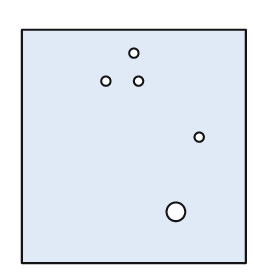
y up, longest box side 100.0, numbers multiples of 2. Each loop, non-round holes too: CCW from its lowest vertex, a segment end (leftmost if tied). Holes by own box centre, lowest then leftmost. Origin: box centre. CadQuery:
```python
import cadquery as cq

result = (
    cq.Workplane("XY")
    .moveTo(-48.0, -50.0)
    .lineTo(48.0, -50.0)
    .lineTo(48.0, 50.0)
    .lineTo(-48.0, 50.0)
    .close()
    .moveTo(18.0, -28.0)
    .circle(4.0)
    .moveTo(28.0, 4.0)
    .circle(2.0)
    .moveTo(-12.0, 28.0)
    .circle(2.0)
    .moveTo(2.0, 28.0)
    .circle(2.0)
    .moveTo(0.0, 40.0)
    .circle(2.0)
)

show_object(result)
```